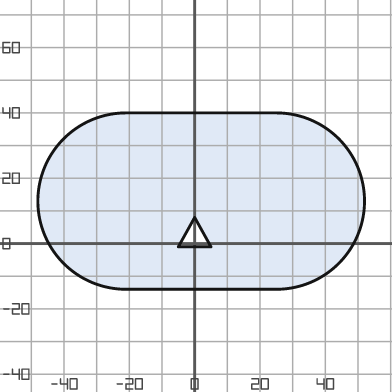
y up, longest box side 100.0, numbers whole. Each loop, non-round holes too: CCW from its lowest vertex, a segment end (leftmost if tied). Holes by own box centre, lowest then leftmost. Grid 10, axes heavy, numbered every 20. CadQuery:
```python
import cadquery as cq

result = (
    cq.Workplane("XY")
    .moveTo(-21.0, -14.0)
    .lineTo(25.0, -14.0)
    .threePointArc((52.0, 13.0), (25.0, 40.0))
    .lineTo(-21.0, 40.0)
    .threePointArc((-48.0, 13.0), (-21.0, -14.0))
    .close()
    .moveTo(-5.0, -1.0)
    .lineTo(5.0, -1.0)
    .lineTo(0.0, 8.0)
    .close()
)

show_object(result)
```